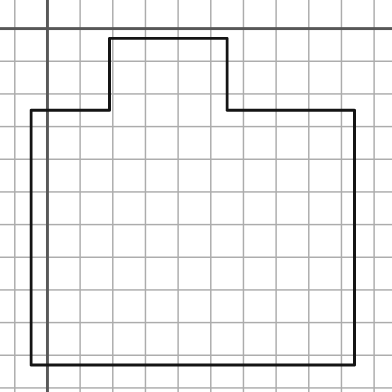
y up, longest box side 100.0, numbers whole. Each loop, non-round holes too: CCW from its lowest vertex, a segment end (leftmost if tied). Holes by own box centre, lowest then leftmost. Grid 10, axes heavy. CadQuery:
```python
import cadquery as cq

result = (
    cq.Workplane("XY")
    .moveTo(-5.0, -103.0)
    .lineTo(94.0, -103.0)
    .lineTo(94.0, -25.0)
    .lineTo(55.0, -25.0)
    .lineTo(55.0, -3.0)
    .lineTo(19.0, -3.0)
    .lineTo(19.0, -25.0)
    .lineTo(-5.0, -25.0)
    .close()
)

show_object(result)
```